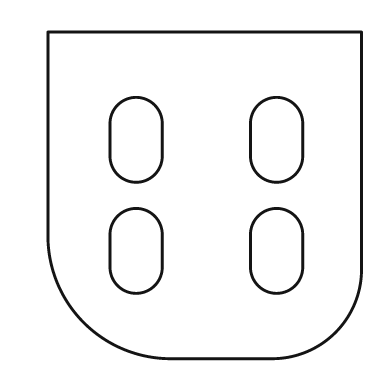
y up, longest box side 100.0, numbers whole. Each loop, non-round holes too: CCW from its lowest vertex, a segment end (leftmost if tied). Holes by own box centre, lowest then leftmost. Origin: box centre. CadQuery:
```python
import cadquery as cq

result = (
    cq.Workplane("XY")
    .moveTo(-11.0, -50.0)
    .lineTo(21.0, -50.0)
    .threePointArc((40.0, -42.0), (48.0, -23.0))
    .lineTo(48.0, 50.0)
    .lineTo(-48.0, 50.0)
    .lineTo(-48.0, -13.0)
    .threePointArc((-37.0, -39.0), (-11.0, -50.0))
    .close()
    .moveTo(-29.0, -22.0)
    .threePointArc((-21.0, -30.0), (-13.0, -22.0))
    .lineTo(-13.0, -12.0)
    .threePointArc((-21.0, -4.0), (-29.0, -12.0))
    .close()
    .moveTo(14.0, -22.0)
    .threePointArc((22.0, -30.0), (30.0, -22.0))
    .lineTo(30.0, -12.0)
    .threePointArc((22.0, -4.0), (14.0, -12.0))
    .close()
    .moveTo(-29.0, 12.0)
    .threePointArc((-21.0, 4.0), (-13.0, 12.0))
    .lineTo(-13.0, 22.0)
    .threePointArc((-21.0, 30.0), (-29.0, 22.0))
    .close()
    .moveTo(14.0, 12.0)
    .threePointArc((22.0, 4.0), (30.0, 12.0))
    .lineTo(30.0, 22.0)
    .threePointArc((22.0, 30.0), (14.0, 22.0))
    .close()
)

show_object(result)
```